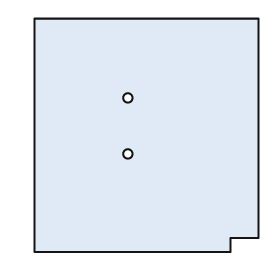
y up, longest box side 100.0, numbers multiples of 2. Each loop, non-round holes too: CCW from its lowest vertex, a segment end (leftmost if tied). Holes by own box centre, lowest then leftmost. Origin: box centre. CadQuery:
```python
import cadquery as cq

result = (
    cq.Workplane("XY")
    .moveTo(-48.0, -50.0)
    .lineTo(36.0, -50.0)
    .lineTo(36.0, -44.0)
    .lineTo(48.0, -44.0)
    .lineTo(48.0, 50.0)
    .lineTo(-48.0, 50.0)
    .close()
    .moveTo(-8.0, -8.0)
    .circle(2.0)
    .moveTo(-8.0, 16.0)
    .circle(2.0)
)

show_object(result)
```